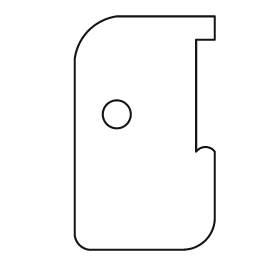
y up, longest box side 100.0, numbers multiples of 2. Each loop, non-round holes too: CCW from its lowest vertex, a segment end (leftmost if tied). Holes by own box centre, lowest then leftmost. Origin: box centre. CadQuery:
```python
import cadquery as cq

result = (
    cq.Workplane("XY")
    .moveTo(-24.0, -50.0)
    .lineTo(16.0, -50.0)
    .threePointArc((26.0, -46.0), (30.0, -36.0))
    .lineTo(30.0, -8.0)
    .threePointArc((26.0, -6.0), (22.0, -8.0))
    .lineTo(22.0, 40.0)
    .lineTo(30.0, 40.0)
    .lineTo(30.0, 50.0)
    .lineTo(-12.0, 50.0)
    .threePointArc((-24.0, 44.0), (-30.0, 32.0))
    .lineTo(-30.0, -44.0)
    .threePointArc((-28.0, -48.0), (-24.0, -50.0))
    .close()
    .moveTo(-12.0, 8.0)
    .circle(6.0)
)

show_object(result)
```